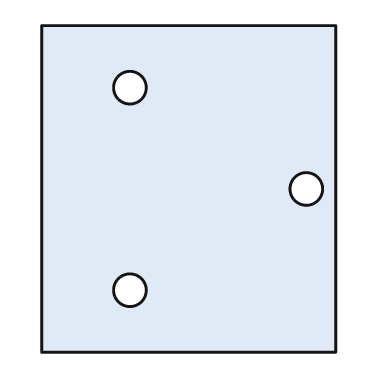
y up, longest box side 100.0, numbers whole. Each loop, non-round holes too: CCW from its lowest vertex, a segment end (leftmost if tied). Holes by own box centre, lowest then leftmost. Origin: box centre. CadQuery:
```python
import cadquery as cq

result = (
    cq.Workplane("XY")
    .moveTo(-45.0, -50.0)
    .lineTo(45.0, -50.0)
    .lineTo(45.0, 50.0)
    .lineTo(-45.0, 50.0)
    .close()
    .moveTo(-18.0, -31.0)
    .circle(5.0)
    .moveTo(36.0, 0.0)
    .circle(5.0)
    .moveTo(-18.0, 31.0)
    .circle(5.0)
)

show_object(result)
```